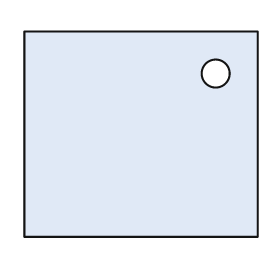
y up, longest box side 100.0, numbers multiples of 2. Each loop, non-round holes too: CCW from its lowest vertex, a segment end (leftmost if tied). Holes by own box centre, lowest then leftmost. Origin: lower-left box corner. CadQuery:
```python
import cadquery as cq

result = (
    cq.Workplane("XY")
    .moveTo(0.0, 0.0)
    .lineTo(100.0, 0.0)
    .lineTo(100.0, 88.0)
    .lineTo(0.0, 88.0)
    .close()
    .moveTo(82.0, 70.0)
    .circle(6.0)
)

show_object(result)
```